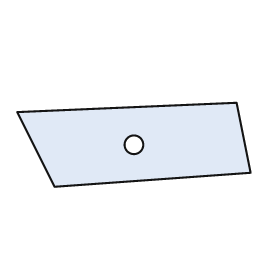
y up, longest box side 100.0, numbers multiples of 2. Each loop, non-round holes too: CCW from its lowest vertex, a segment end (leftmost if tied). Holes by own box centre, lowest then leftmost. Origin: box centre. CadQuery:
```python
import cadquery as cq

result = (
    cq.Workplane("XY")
    .moveTo(-34.0, -18.0)
    .lineTo(50.0, -12.0)
    .lineTo(44.0, 18.0)
    .lineTo(-50.0, 14.0)
    .close()
    .moveTo(0.0, 0.0)
    .circle(4.0)
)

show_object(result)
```